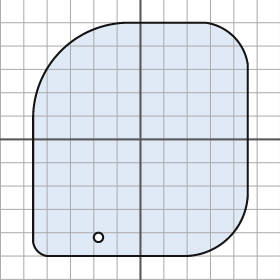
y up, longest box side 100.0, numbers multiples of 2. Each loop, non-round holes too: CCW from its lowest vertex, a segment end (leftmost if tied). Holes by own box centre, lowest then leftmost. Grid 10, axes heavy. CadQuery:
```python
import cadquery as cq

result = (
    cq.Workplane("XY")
    .moveTo(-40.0, -50.0)
    .lineTo(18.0, -50.0)
    .threePointArc((38.0, -42.0), (46.0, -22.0))
    .lineTo(46.0, 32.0)
    .threePointArc((40.0, 44.0), (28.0, 50.0))
    .lineTo(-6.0, 50.0)
    .threePointArc((-34.0, 38.0), (-46.0, 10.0))
    .lineTo(-46.0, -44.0)
    .threePointArc((-44.0, -48.0), (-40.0, -50.0))
    .close()
    .moveTo(-18.0, -42.0)
    .circle(2.0)
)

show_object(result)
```